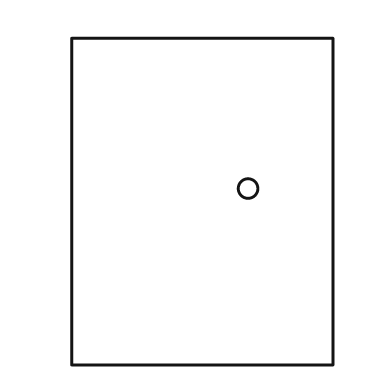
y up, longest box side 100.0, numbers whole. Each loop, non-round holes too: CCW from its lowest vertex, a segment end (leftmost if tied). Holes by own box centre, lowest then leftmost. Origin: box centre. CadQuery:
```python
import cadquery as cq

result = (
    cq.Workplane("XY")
    .moveTo(-40.0, -50.0)
    .lineTo(40.0, -50.0)
    .lineTo(40.0, 50.0)
    .lineTo(-40.0, 50.0)
    .close()
    .moveTo(14.0, 4.0)
    .circle(3.0)
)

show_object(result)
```